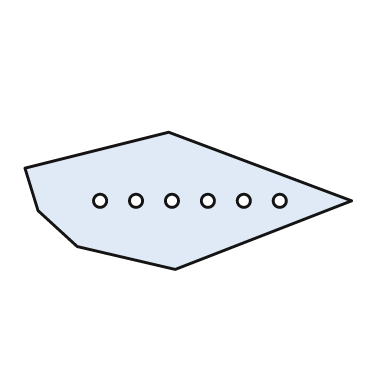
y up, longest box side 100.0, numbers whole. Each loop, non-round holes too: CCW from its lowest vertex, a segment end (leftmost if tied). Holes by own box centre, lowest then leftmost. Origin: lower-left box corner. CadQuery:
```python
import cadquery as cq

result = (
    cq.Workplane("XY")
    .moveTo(46.0, 0.0)
    .lineTo(100.0, 21.0)
    .lineTo(44.0, 42.0)
    .lineTo(0.0, 31.0)
    .lineTo(4.0, 18.0)
    .lineTo(16.0, 7.0)
    .close()
    .moveTo(23.0, 21.0)
    .circle(2.0)
    .moveTo(34.0, 21.0)
    .circle(2.0)
    .moveTo(45.0, 21.0)
    .circle(2.0)
    .moveTo(56.0, 21.0)
    .circle(2.0)
    .moveTo(67.0, 21.0)
    .circle(2.0)
    .moveTo(78.0, 21.0)
    .circle(2.0)
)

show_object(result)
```